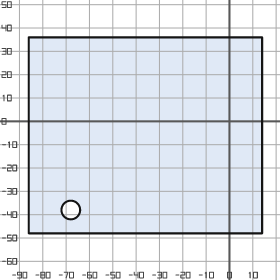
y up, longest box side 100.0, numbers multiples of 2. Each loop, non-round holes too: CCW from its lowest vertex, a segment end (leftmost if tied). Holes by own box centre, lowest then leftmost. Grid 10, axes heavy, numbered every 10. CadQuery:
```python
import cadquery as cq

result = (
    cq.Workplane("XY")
    .moveTo(-86.0, -48.0)
    .lineTo(14.0, -48.0)
    .lineTo(14.0, 36.0)
    .lineTo(-86.0, 36.0)
    .close()
    .moveTo(-68.0, -38.0)
    .circle(4.0)
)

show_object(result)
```